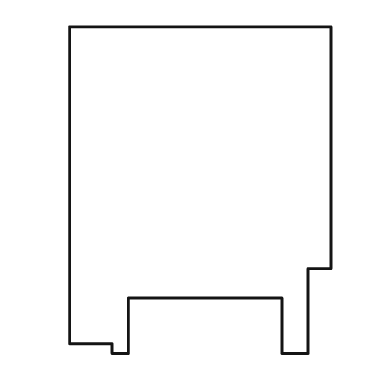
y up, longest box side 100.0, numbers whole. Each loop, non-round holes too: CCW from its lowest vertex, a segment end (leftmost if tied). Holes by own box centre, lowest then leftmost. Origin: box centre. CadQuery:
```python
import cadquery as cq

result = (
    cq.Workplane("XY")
    .moveTo(-27.0, -50.0)
    .lineTo(-22.0, -50.0)
    .lineTo(-22.0, -33.0)
    .lineTo(25.0, -33.0)
    .lineTo(25.0, -50.0)
    .lineTo(33.0, -50.0)
    .lineTo(33.0, -24.0)
    .lineTo(40.0, -24.0)
    .lineTo(40.0, 50.0)
    .lineTo(-40.0, 50.0)
    .lineTo(-40.0, -47.0)
    .lineTo(-27.0, -47.0)
    .close()
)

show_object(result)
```